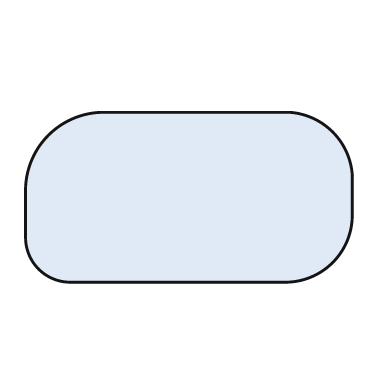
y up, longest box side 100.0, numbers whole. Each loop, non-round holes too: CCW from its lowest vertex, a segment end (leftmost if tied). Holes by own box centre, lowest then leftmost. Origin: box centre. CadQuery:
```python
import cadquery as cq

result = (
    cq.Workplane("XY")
    .moveTo(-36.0, -26.0)
    .lineTo(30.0, -26.0)
    .threePointArc((44.0, -20.0), (50.0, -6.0))
    .lineTo(50.0, 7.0)
    .threePointArc((44.0, 20.0), (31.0, 26.0))
    .lineTo(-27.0, 26.0)
    .threePointArc((-43.0, 19.0), (-50.0, 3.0))
    .lineTo(-50.0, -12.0)
    .threePointArc((-46.0, -22.0), (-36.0, -26.0))
    .close()
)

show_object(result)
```